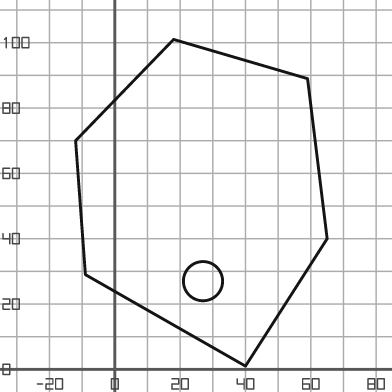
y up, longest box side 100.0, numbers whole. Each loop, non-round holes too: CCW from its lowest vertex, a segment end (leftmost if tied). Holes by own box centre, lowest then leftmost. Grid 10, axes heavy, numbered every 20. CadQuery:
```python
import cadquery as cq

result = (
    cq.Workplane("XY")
    .moveTo(40.0, 1.0)
    .lineTo(65.0, 40.0)
    .lineTo(59.0, 89.0)
    .lineTo(18.0, 101.0)
    .lineTo(-12.0, 70.0)
    .lineTo(-9.0, 29.0)
    .close()
    .moveTo(27.0, 27.0)
    .circle(6.0)
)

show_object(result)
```